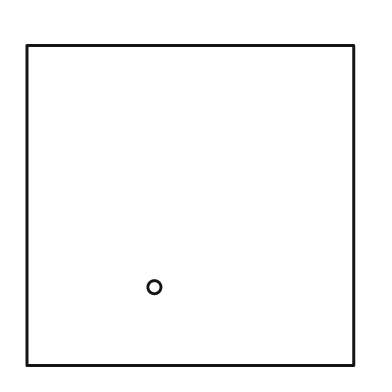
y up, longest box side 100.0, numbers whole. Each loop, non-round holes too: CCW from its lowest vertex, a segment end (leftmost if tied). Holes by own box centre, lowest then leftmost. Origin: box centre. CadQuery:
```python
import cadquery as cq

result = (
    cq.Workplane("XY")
    .moveTo(-50.0, -49.0)
    .lineTo(50.0, -49.0)
    .lineTo(50.0, 49.0)
    .lineTo(-50.0, 49.0)
    .close()
    .moveTo(-11.0, -25.0)
    .circle(2.0)
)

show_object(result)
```